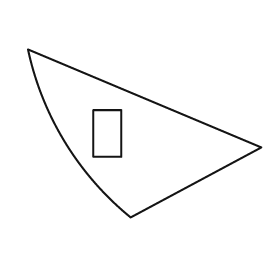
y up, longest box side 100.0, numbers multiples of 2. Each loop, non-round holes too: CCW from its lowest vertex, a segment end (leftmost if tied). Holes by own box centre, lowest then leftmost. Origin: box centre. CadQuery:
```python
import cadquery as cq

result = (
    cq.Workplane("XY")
    .moveTo(-6.0, -36.0)
    .lineTo(50.0, -6.0)
    .lineTo(-50.0, 36.0)
    .threePointArc((-34.0, -4.0), (-6.0, -36.0))
    .close()
    .moveTo(-22.0, -10.0)
    .lineTo(-10.0, -10.0)
    .lineTo(-10.0, 10.0)
    .lineTo(-22.0, 10.0)
    .close()
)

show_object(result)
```